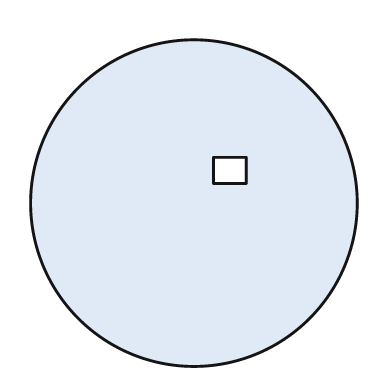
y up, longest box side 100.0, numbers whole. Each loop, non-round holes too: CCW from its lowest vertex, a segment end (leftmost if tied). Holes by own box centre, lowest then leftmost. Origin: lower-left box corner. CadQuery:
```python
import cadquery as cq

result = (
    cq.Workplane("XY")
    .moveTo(50.0, 50.0)
    .circle(50.0)
    .moveTo(56.0, 56.0)
    .lineTo(66.0, 56.0)
    .lineTo(66.0, 64.0)
    .lineTo(56.0, 64.0)
    .close()
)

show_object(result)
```